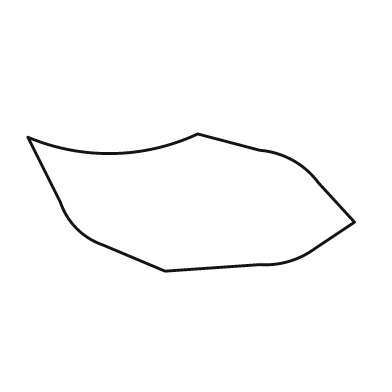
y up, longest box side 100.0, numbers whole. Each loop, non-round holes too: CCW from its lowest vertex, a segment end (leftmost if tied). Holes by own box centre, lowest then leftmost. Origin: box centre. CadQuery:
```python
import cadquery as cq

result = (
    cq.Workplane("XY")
    .moveTo(-8.0, -21.0)
    .lineTo(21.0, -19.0)
    .threePointArc((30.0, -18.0), (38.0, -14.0))
    .lineTo(50.0, -6.0)
    .lineTo(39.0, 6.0)
    .threePointArc((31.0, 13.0), (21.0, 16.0))
    .lineTo(2.0, 21.0)
    .threePointArc((-24.0, 15.0), (-50.0, 20.0))
    .lineTo(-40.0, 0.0)
    .threePointArc((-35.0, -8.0), (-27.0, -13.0))
    .close()
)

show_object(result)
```